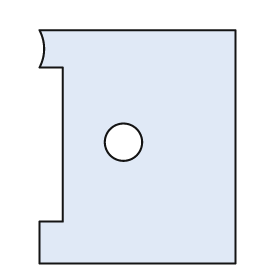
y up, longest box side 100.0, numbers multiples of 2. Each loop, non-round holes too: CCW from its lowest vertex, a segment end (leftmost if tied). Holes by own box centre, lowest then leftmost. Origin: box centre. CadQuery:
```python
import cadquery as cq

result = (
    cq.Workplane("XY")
    .moveTo(-42.0, -50.0)
    .lineTo(42.0, -50.0)
    .lineTo(42.0, 50.0)
    .lineTo(-42.0, 50.0)
    .threePointArc((-40.0, 42.0), (-42.0, 34.0))
    .lineTo(-32.0, 34.0)
    .lineTo(-32.0, -32.0)
    .lineTo(-42.0, -32.0)
    .close()
    .moveTo(-6.0, 2.0)
    .circle(8.0)
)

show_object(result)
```